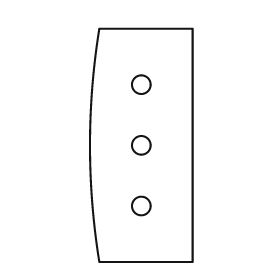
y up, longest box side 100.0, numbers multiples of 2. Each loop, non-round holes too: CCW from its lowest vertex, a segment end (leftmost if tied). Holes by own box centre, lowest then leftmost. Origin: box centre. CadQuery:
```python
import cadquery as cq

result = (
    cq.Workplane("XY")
    .moveTo(-18.0, -50.0)
    .lineTo(22.0, -50.0)
    .lineTo(22.0, 50.0)
    .lineTo(-18.0, 50.0)
    .threePointArc((-22.0, 0.0), (-18.0, -50.0))
    .close()
    .moveTo(0.0, -26.0)
    .circle(4.0)
    .moveTo(0.0, 0.0)
    .circle(4.0)
    .moveTo(0.0, 26.0)
    .circle(4.0)
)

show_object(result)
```